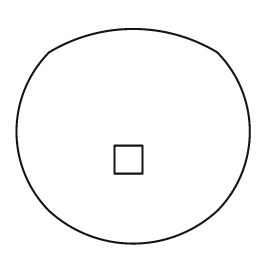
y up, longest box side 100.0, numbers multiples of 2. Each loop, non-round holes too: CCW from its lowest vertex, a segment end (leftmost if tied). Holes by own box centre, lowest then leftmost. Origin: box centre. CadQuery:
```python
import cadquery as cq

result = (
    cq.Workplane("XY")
    .moveTo(-36.0, -32.0)
    .threePointArc((0.0, -46.0), (36.0, -32.0))
    .threePointArc((50.0, 2.0), (36.0, 36.0))
    .threePointArc((0.0, 46.0), (-36.0, 36.0))
    .threePointArc((-50.0, 2.0), (-36.0, -32.0))
    .close()
    .moveTo(-8.0, -16.0)
    .lineTo(4.0, -16.0)
    .lineTo(4.0, -4.0)
    .lineTo(-8.0, -4.0)
    .close()
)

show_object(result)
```